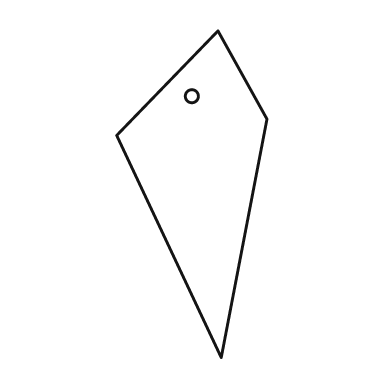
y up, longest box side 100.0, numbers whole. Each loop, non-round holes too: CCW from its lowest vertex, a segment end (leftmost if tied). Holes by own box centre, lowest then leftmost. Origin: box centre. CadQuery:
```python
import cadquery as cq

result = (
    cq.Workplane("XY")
    .moveTo(9.0, -50.0)
    .lineTo(23.0, 23.0)
    .lineTo(8.0, 50.0)
    .lineTo(-23.0, 18.0)
    .close()
    .moveTo(0.0, 30.0)
    .circle(2.0)
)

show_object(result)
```